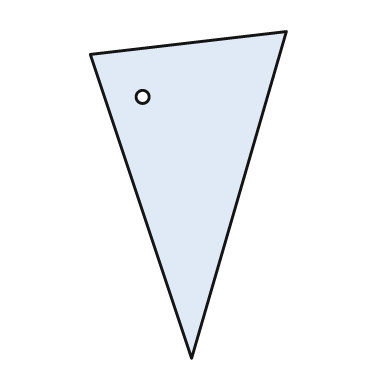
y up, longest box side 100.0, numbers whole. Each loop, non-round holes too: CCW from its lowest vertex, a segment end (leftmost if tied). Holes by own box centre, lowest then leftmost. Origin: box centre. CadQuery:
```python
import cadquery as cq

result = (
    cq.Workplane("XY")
    .moveTo(1.0, -50.0)
    .lineTo(30.0, 50.0)
    .lineTo(-30.0, 43.0)
    .close()
    .moveTo(-14.0, 30.0)
    .circle(2.0)
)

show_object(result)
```